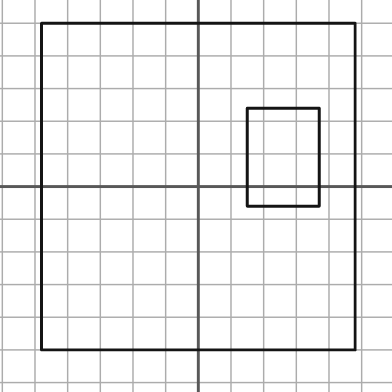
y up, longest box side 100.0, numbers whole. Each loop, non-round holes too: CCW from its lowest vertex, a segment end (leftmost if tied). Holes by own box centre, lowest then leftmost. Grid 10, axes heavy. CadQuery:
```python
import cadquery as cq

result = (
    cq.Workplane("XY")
    .moveTo(-48.0, -50.0)
    .lineTo(48.0, -50.0)
    .lineTo(48.0, 50.0)
    .lineTo(-48.0, 50.0)
    .close()
    .moveTo(15.0, -6.0)
    .lineTo(37.0, -6.0)
    .lineTo(37.0, 24.0)
    .lineTo(15.0, 24.0)
    .close()
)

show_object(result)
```